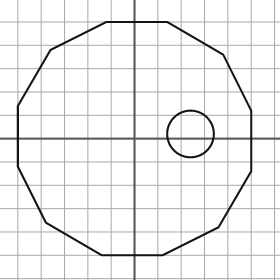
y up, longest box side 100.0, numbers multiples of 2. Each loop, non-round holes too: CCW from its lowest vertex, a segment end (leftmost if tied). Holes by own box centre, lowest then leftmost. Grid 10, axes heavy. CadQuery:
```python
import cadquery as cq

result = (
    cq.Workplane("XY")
    .moveTo(-14.0, -50.0)
    .lineTo(12.0, -50.0)
    .lineTo(36.0, -38.0)
    .lineTo(50.0, -14.0)
    .lineTo(50.0, 12.0)
    .lineTo(38.0, 36.0)
    .lineTo(14.0, 50.0)
    .lineTo(-12.0, 50.0)
    .lineTo(-36.0, 38.0)
    .lineTo(-50.0, 14.0)
    .lineTo(-50.0, -12.0)
    .lineTo(-38.0, -36.0)
    .close()
    .moveTo(24.0, 2.0)
    .circle(10.0)
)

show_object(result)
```